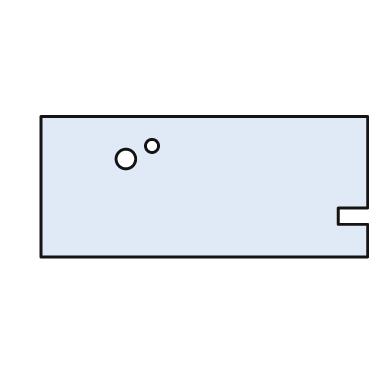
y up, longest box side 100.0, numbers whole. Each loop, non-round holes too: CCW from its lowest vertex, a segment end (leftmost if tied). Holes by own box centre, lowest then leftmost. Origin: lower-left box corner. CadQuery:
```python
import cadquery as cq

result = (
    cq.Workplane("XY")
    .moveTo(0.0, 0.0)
    .lineTo(100.0, 0.0)
    .lineTo(100.0, 10.0)
    .lineTo(91.0, 10.0)
    .lineTo(91.0, 15.0)
    .lineTo(100.0, 15.0)
    .lineTo(100.0, 43.0)
    .lineTo(0.0, 43.0)
    .close()
    .moveTo(26.0, 30.0)
    .circle(3.0)
    .moveTo(34.0, 34.0)
    .circle(2.0)
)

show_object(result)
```